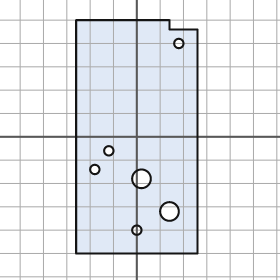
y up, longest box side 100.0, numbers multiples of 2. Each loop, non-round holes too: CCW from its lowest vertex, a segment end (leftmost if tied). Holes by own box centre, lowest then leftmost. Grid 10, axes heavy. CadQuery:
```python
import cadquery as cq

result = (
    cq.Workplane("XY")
    .moveTo(-26.0, -50.0)
    .lineTo(26.0, -50.0)
    .lineTo(26.0, 46.0)
    .lineTo(14.0, 46.0)
    .lineTo(14.0, 50.0)
    .lineTo(-26.0, 50.0)
    .close()
    .moveTo(0.0, -40.0)
    .circle(2.0)
    .moveTo(14.0, -32.0)
    .circle(4.0)
    .moveTo(2.0, -18.0)
    .circle(4.0)
    .moveTo(-18.0, -14.0)
    .circle(2.0)
    .moveTo(-12.0, -6.0)
    .circle(2.0)
    .moveTo(18.0, 40.0)
    .circle(2.0)
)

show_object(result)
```